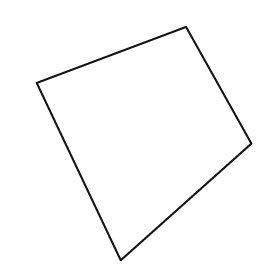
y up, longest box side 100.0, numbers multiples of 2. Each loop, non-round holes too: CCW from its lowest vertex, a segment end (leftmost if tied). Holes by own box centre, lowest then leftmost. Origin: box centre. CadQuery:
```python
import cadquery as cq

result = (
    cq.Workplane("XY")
    .moveTo(-10.0, -50.0)
    .lineTo(46.0, 0.0)
    .lineTo(18.0, 50.0)
    .lineTo(-46.0, 26.0)
    .close()
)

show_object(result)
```